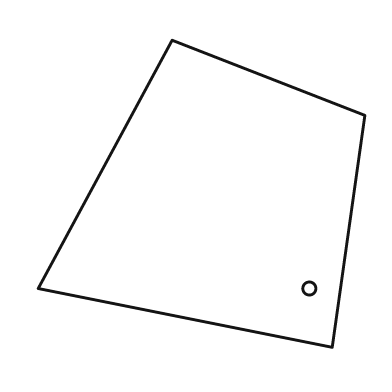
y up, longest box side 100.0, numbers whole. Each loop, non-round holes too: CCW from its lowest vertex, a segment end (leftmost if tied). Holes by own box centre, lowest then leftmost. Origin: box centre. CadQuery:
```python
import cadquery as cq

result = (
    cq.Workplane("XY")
    .moveTo(40.0, -47.0)
    .lineTo(50.0, 24.0)
    .lineTo(-9.0, 47.0)
    .lineTo(-50.0, -29.0)
    .close()
    .moveTo(33.0, -29.0)
    .circle(2.0)
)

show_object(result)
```